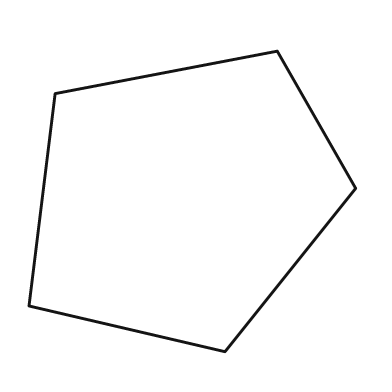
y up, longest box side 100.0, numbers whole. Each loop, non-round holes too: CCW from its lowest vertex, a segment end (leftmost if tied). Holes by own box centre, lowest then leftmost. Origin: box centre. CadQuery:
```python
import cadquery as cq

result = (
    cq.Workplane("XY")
    .moveTo(10.0, -46.0)
    .lineTo(50.0, 4.0)
    .lineTo(26.0, 46.0)
    .lineTo(-42.0, 33.0)
    .lineTo(-50.0, -32.0)
    .close()
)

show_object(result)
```